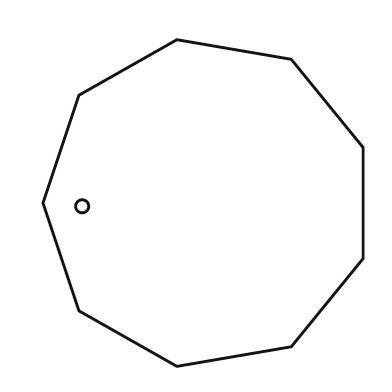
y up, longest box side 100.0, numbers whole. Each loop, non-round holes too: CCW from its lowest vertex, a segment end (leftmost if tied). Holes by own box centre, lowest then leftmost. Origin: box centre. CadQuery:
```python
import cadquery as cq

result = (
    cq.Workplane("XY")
    .moveTo(-8.0, -50.0)
    .lineTo(27.0, -44.0)
    .lineTo(49.0, -17.0)
    .lineTo(49.0, 17.0)
    .lineTo(27.0, 44.0)
    .lineTo(-8.0, 50.0)
    .lineTo(-38.0, 33.0)
    .lineTo(-49.0, 0.0)
    .lineTo(-38.0, -33.0)
    .close()
    .moveTo(-37.0, -1.0)
    .circle(2.0)
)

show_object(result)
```